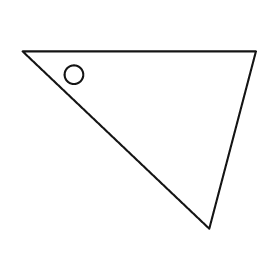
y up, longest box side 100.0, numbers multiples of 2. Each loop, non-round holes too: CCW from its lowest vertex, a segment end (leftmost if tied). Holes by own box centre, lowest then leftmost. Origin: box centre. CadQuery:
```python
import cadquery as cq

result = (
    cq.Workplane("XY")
    .moveTo(30.0, -38.0)
    .lineTo(50.0, 38.0)
    .lineTo(-50.0, 38.0)
    .close()
    .moveTo(-28.0, 28.0)
    .circle(4.0)
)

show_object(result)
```